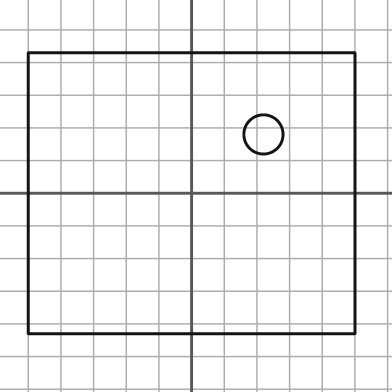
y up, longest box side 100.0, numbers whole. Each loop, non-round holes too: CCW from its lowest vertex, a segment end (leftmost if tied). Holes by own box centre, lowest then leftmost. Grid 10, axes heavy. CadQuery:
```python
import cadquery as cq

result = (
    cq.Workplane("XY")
    .moveTo(-50.0, -43.0)
    .lineTo(50.0, -43.0)
    .lineTo(50.0, 43.0)
    .lineTo(-50.0, 43.0)
    .close()
    .moveTo(22.0, 18.0)
    .circle(6.0)
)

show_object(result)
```